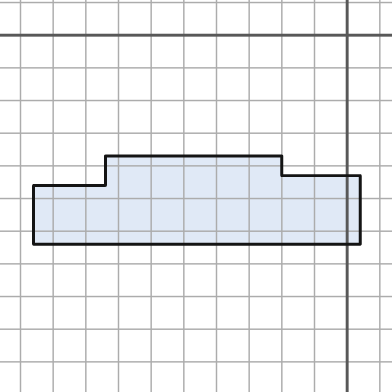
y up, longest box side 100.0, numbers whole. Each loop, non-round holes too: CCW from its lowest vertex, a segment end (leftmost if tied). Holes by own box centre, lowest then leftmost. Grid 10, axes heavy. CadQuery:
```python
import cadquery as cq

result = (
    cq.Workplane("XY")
    .moveTo(-96.0, -64.0)
    .lineTo(4.0, -64.0)
    .lineTo(4.0, -43.0)
    .lineTo(-20.0, -43.0)
    .lineTo(-20.0, -37.0)
    .lineTo(-74.0, -37.0)
    .lineTo(-74.0, -46.0)
    .lineTo(-96.0, -46.0)
    .close()
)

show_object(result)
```